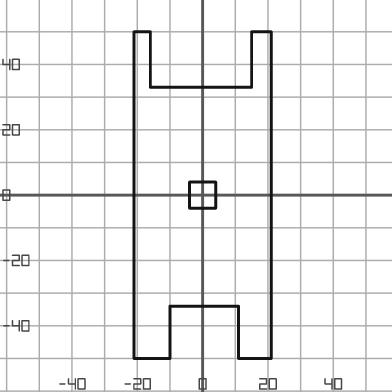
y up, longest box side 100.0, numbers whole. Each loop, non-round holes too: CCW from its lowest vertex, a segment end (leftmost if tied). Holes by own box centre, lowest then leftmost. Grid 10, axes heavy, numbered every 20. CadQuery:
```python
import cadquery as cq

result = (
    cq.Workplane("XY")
    .moveTo(-21.0, -50.0)
    .lineTo(-10.0, -50.0)
    .lineTo(-10.0, -34.0)
    .lineTo(11.0, -34.0)
    .lineTo(11.0, -50.0)
    .lineTo(21.0, -50.0)
    .lineTo(21.0, 50.0)
    .lineTo(15.0, 50.0)
    .lineTo(15.0, 33.0)
    .lineTo(-16.0, 33.0)
    .lineTo(-16.0, 50.0)
    .lineTo(-21.0, 50.0)
    .close()
    .moveTo(-4.0, -4.0)
    .lineTo(4.0, -4.0)
    .lineTo(4.0, 4.0)
    .lineTo(-4.0, 4.0)
    .close()
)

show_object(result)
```